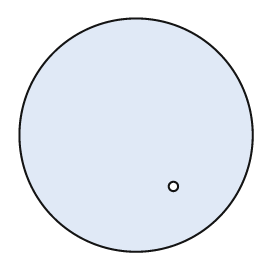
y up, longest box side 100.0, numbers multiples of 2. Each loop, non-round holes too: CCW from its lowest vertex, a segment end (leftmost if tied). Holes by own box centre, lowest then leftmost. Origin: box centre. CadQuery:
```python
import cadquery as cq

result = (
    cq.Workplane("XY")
    .moveTo(0.0, 0.0)
    .circle(50.0)
    .moveTo(16.0, -22.0)
    .circle(2.0)
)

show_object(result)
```